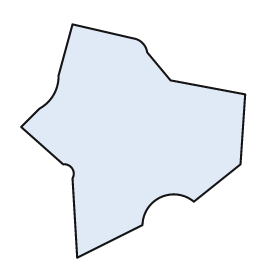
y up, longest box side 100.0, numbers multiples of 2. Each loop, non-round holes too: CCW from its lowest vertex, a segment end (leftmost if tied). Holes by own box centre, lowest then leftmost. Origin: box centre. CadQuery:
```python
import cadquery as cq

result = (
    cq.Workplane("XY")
    .moveTo(-24.0, -50.0)
    .lineTo(4.0, -36.0)
    .threePointArc((12.0, -24.0), (26.0, -26.0))
    .lineTo(46.0, -10.0)
    .lineTo(48.0, 20.0)
    .lineTo(16.0, 26.0)
    .lineTo(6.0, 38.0)
    .threePointArc((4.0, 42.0), (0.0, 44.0))
    .lineTo(-26.0, 50.0)
    .lineTo(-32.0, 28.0)
    .threePointArc((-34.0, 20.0), (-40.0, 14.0))
    .lineTo(-48.0, 6.0)
    .lineTo(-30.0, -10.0)
    .threePointArc((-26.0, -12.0), (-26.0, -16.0))
    .close()
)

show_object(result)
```